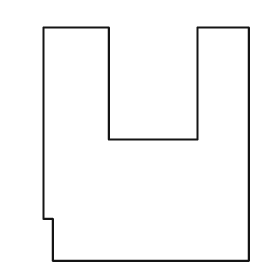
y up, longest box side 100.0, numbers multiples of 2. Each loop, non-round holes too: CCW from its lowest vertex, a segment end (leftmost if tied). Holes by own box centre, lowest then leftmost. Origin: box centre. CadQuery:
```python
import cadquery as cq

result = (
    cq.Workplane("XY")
    .moveTo(-40.0, -50.0)
    .lineTo(44.0, -50.0)
    .lineTo(44.0, 50.0)
    .lineTo(22.0, 50.0)
    .lineTo(22.0, 2.0)
    .lineTo(-16.0, 2.0)
    .lineTo(-16.0, 50.0)
    .lineTo(-44.0, 50.0)
    .lineTo(-44.0, -32.0)
    .lineTo(-40.0, -32.0)
    .close()
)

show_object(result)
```